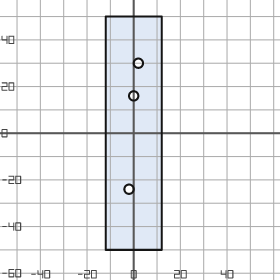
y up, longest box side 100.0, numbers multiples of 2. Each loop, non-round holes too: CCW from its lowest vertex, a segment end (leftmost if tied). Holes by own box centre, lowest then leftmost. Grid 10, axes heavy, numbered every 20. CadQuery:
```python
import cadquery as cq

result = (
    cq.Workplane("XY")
    .moveTo(-12.0, -50.0)
    .lineTo(12.0, -50.0)
    .lineTo(12.0, 50.0)
    .lineTo(-12.0, 50.0)
    .close()
    .moveTo(-2.0, -24.0)
    .circle(2.0)
    .moveTo(0.0, 16.0)
    .circle(2.0)
    .moveTo(2.0, 30.0)
    .circle(2.0)
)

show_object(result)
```